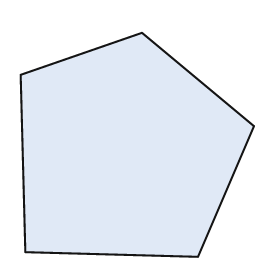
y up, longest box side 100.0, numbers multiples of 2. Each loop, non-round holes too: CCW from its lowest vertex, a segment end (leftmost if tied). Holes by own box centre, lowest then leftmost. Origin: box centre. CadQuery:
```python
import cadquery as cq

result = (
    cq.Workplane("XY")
    .moveTo(26.0, -48.0)
    .lineTo(50.0, 8.0)
    .lineTo(2.0, 48.0)
    .lineTo(-50.0, 30.0)
    .lineTo(-48.0, -46.0)
    .close()
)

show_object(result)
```